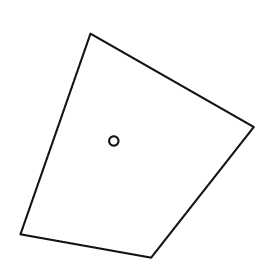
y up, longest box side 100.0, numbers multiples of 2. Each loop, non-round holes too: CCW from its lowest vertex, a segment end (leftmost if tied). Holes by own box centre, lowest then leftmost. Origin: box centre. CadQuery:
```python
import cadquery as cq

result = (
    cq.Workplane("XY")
    .moveTo(6.0, -48.0)
    .lineTo(50.0, 8.0)
    .lineTo(-20.0, 48.0)
    .lineTo(-50.0, -38.0)
    .close()
    .moveTo(-10.0, 2.0)
    .circle(2.0)
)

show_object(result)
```